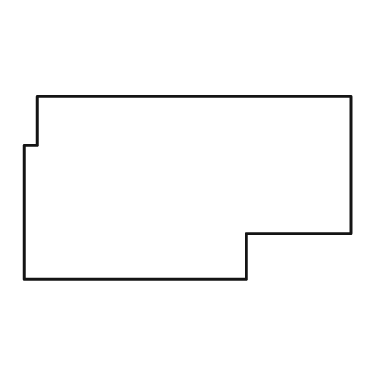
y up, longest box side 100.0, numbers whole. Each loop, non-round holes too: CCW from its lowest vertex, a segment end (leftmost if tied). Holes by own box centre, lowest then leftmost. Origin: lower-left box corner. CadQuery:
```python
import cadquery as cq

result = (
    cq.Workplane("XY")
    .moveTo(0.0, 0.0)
    .lineTo(68.0, 0.0)
    .lineTo(68.0, 14.0)
    .lineTo(100.0, 14.0)
    .lineTo(100.0, 56.0)
    .lineTo(4.0, 56.0)
    .lineTo(4.0, 41.0)
    .lineTo(0.0, 41.0)
    .close()
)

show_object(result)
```